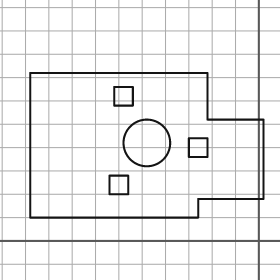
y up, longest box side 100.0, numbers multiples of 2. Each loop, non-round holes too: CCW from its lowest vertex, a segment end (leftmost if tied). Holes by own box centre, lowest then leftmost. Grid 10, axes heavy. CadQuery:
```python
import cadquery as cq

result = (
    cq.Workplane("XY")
    .moveTo(-98.0, 10.0)
    .lineTo(-26.0, 10.0)
    .lineTo(-26.0, 18.0)
    .lineTo(2.0, 18.0)
    .lineTo(2.0, 52.0)
    .lineTo(-22.0, 52.0)
    .lineTo(-22.0, 72.0)
    .lineTo(-98.0, 72.0)
    .close()
    .moveTo(-64.0, 20.0)
    .lineTo(-56.0, 20.0)
    .lineTo(-56.0, 28.0)
    .lineTo(-64.0, 28.0)
    .close()
    .moveTo(-30.0, 36.0)
    .lineTo(-22.0, 36.0)
    .lineTo(-22.0, 44.0)
    .lineTo(-30.0, 44.0)
    .close()
    .moveTo(-48.0, 42.0)
    .circle(10.0)
    .moveTo(-62.0, 58.0)
    .lineTo(-54.0, 58.0)
    .lineTo(-54.0, 66.0)
    .lineTo(-62.0, 66.0)
    .close()
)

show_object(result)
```